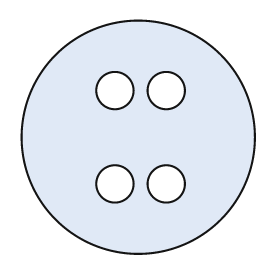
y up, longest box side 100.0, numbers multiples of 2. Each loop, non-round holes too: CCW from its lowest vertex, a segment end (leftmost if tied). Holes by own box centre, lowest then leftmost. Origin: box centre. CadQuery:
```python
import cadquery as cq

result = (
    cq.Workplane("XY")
    .moveTo(0.0, 0.0)
    .circle(50.0)
    .moveTo(-10.0, -20.0)
    .circle(8.0)
    .moveTo(12.0, -20.0)
    .circle(8.0)
    .moveTo(-10.0, 20.0)
    .circle(8.0)
    .moveTo(12.0, 20.0)
    .circle(8.0)
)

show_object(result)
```